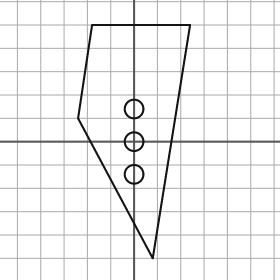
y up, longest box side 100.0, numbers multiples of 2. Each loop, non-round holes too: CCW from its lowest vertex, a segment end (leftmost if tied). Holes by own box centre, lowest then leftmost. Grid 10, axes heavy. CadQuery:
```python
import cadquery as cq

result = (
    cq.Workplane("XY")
    .moveTo(8.0, -50.0)
    .lineTo(24.0, 50.0)
    .lineTo(-18.0, 50.0)
    .lineTo(-24.0, 10.0)
    .close()
    .moveTo(0.0, -14.0)
    .circle(4.0)
    .moveTo(0.0, 0.0)
    .circle(4.0)
    .moveTo(0.0, 14.0)
    .circle(4.0)
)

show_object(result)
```